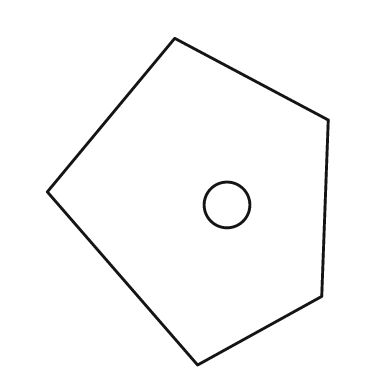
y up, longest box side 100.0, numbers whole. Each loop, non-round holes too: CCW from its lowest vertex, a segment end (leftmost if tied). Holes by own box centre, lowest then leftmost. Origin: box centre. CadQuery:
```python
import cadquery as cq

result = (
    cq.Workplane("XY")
    .moveTo(3.0, -50.0)
    .lineTo(41.0, -29.0)
    .lineTo(43.0, 25.0)
    .lineTo(-4.0, 50.0)
    .lineTo(-43.0, 3.0)
    .close()
    .moveTo(12.0, -1.0)
    .circle(7.0)
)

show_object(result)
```